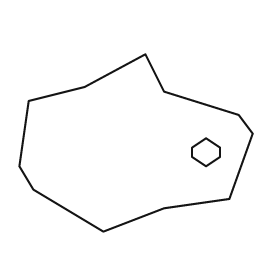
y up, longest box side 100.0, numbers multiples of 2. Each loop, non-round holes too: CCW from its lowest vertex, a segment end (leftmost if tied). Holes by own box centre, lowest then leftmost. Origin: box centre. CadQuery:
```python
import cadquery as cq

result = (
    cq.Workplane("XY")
    .moveTo(-14.0, -38.0)
    .lineTo(12.0, -28.0)
    .lineTo(40.0, -24.0)
    .lineTo(50.0, 4.0)
    .lineTo(44.0, 12.0)
    .lineTo(12.0, 22.0)
    .lineTo(4.0, 38.0)
    .lineTo(-22.0, 24.0)
    .lineTo(-46.0, 18.0)
    .lineTo(-50.0, -10.0)
    .lineTo(-44.0, -20.0)
    .close()
    .moveTo(30.0, -10.0)
    .lineTo(36.0, -6.0)
    .lineTo(36.0, -2.0)
    .lineTo(30.0, 2.0)
    .lineTo(24.0, -2.0)
    .lineTo(24.0, -6.0)
    .close()
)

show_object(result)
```